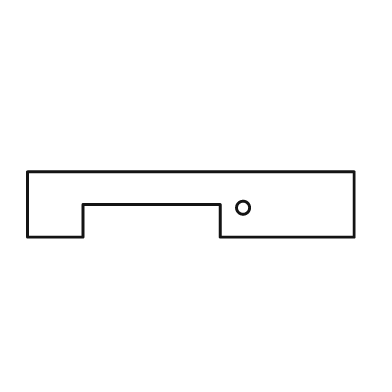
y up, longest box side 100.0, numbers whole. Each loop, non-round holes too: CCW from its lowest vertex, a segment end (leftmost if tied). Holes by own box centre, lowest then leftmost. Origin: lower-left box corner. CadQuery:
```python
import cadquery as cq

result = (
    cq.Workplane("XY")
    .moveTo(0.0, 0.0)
    .lineTo(17.0, 0.0)
    .lineTo(17.0, 10.0)
    .lineTo(59.0, 10.0)
    .lineTo(59.0, 0.0)
    .lineTo(100.0, 0.0)
    .lineTo(100.0, 20.0)
    .lineTo(0.0, 20.0)
    .close()
    .moveTo(66.0, 9.0)
    .circle(2.0)
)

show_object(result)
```